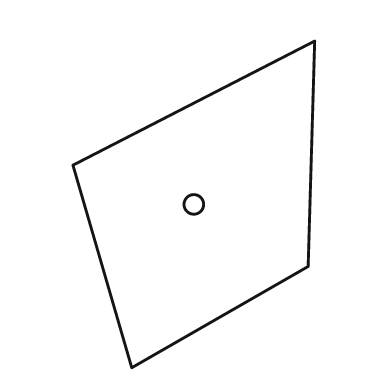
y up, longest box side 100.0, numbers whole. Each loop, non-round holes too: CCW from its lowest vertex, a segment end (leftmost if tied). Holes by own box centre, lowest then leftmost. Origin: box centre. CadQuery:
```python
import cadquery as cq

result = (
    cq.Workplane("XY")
    .moveTo(-19.0, -50.0)
    .lineTo(35.0, -19.0)
    .lineTo(37.0, 50.0)
    .lineTo(-37.0, 12.0)
    .close()
    .moveTo(0.0, 0.0)
    .circle(3.0)
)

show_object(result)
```